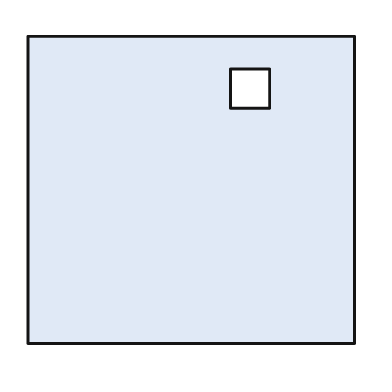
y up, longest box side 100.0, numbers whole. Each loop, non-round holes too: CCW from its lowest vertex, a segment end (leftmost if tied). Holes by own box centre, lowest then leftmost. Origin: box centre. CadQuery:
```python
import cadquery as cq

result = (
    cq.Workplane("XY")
    .moveTo(-50.0, -47.0)
    .lineTo(50.0, -47.0)
    .lineTo(50.0, 47.0)
    .lineTo(-50.0, 47.0)
    .close()
    .moveTo(12.0, 25.0)
    .lineTo(24.0, 25.0)
    .lineTo(24.0, 37.0)
    .lineTo(12.0, 37.0)
    .close()
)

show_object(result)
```